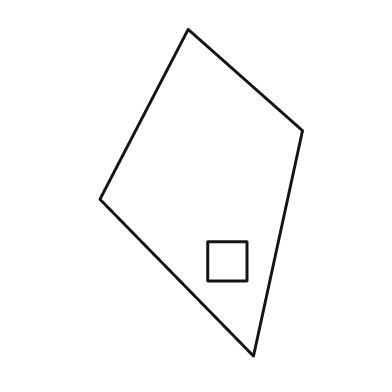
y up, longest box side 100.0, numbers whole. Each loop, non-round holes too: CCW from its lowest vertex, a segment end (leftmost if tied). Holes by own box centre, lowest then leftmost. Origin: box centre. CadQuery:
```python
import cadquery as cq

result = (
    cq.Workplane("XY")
    .moveTo(16.0, -50.0)
    .lineTo(31.0, 19.0)
    .lineTo(-4.0, 50.0)
    .lineTo(-31.0, -2.0)
    .close()
    .moveTo(2.0, -27.0)
    .lineTo(14.0, -27.0)
    .lineTo(14.0, -15.0)
    .lineTo(2.0, -15.0)
    .close()
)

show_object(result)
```